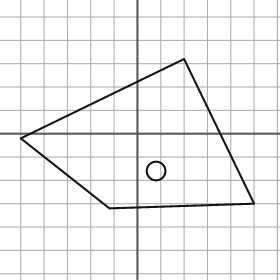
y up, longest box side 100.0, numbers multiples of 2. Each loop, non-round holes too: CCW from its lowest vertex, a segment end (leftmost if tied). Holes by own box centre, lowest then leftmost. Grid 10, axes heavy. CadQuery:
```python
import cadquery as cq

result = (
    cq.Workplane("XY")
    .moveTo(-12.0, -32.0)
    .lineTo(50.0, -30.0)
    .lineTo(20.0, 32.0)
    .lineTo(-50.0, -2.0)
    .close()
    .moveTo(8.0, -16.0)
    .circle(4.0)
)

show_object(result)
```